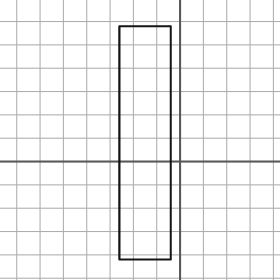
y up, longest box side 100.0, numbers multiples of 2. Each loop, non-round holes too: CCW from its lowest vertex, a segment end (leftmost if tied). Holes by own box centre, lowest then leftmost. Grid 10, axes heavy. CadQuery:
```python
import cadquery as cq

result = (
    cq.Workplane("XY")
    .moveTo(-26.0, -42.0)
    .lineTo(-4.0, -42.0)
    .lineTo(-4.0, 58.0)
    .lineTo(-26.0, 58.0)
    .close()
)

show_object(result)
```